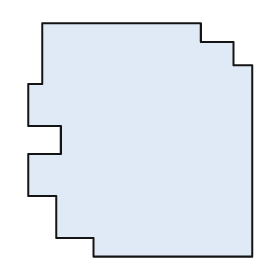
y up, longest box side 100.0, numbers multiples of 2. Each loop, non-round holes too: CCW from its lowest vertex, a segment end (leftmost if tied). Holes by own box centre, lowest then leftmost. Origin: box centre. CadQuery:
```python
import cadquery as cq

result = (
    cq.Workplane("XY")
    .moveTo(-20.0, -50.0)
    .lineTo(48.0, -50.0)
    .lineTo(48.0, 32.0)
    .lineTo(40.0, 32.0)
    .lineTo(40.0, 42.0)
    .lineTo(26.0, 42.0)
    .lineTo(26.0, 50.0)
    .lineTo(-42.0, 50.0)
    .lineTo(-42.0, 24.0)
    .lineTo(-48.0, 24.0)
    .lineTo(-48.0, 6.0)
    .lineTo(-34.0, 6.0)
    .lineTo(-34.0, -6.0)
    .lineTo(-48.0, -6.0)
    .lineTo(-48.0, -24.0)
    .lineTo(-36.0, -24.0)
    .lineTo(-36.0, -42.0)
    .lineTo(-20.0, -42.0)
    .close()
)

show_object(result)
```